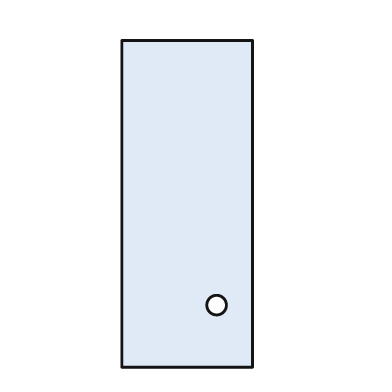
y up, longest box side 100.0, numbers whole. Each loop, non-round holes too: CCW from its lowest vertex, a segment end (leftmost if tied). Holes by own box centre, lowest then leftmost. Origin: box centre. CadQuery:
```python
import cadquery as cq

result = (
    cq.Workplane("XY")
    .moveTo(-20.0, -50.0)
    .lineTo(20.0, -50.0)
    .lineTo(20.0, 50.0)
    .lineTo(-20.0, 50.0)
    .close()
    .moveTo(9.0, -31.0)
    .circle(3.0)
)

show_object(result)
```